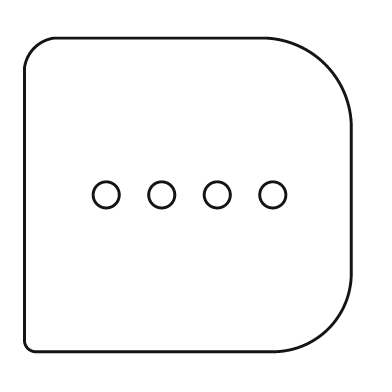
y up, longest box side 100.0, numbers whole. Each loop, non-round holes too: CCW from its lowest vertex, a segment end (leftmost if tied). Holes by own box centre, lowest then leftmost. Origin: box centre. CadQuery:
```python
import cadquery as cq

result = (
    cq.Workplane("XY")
    .moveTo(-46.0, -48.0)
    .lineTo(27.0, -48.0)
    .threePointArc((43.0, -41.0), (50.0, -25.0))
    .lineTo(50.0, 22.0)
    .threePointArc((42.0, 40.0), (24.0, 48.0))
    .lineTo(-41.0, 48.0)
    .threePointArc((-47.0, 45.0), (-50.0, 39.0))
    .lineTo(-50.0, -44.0)
    .threePointArc((-49.0, -47.0), (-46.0, -48.0))
    .close()
    .moveTo(-25.0, 0.0)
    .circle(4.0)
    .moveTo(-8.0, 0.0)
    .circle(4.0)
    .moveTo(9.0, 0.0)
    .circle(4.0)
    .moveTo(26.0, 0.0)
    .circle(4.0)
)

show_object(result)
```